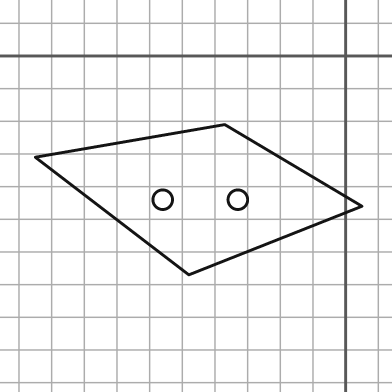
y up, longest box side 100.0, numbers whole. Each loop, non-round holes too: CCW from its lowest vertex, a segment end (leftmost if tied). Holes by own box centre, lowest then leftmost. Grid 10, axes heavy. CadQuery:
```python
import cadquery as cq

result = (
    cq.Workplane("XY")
    .moveTo(-48.0, -67.0)
    .lineTo(5.0, -46.0)
    .lineTo(-37.0, -21.0)
    .lineTo(-95.0, -31.0)
    .close()
    .moveTo(-56.0, -44.0)
    .circle(3.0)
    .moveTo(-33.0, -44.0)
    .circle(3.0)
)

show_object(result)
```